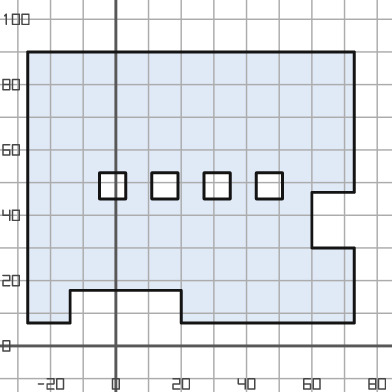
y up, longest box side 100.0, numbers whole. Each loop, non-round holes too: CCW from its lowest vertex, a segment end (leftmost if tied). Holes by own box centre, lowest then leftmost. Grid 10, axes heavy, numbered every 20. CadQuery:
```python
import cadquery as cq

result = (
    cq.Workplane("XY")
    .moveTo(-27.0, 7.0)
    .lineTo(-14.0, 7.0)
    .lineTo(-14.0, 17.0)
    .lineTo(20.0, 17.0)
    .lineTo(20.0, 7.0)
    .lineTo(73.0, 7.0)
    .lineTo(73.0, 30.0)
    .lineTo(60.0, 30.0)
    .lineTo(60.0, 47.0)
    .lineTo(73.0, 47.0)
    .lineTo(73.0, 90.0)
    .lineTo(-27.0, 90.0)
    .close()
    .moveTo(-5.0, 45.0)
    .lineTo(3.0, 45.0)
    .lineTo(3.0, 53.0)
    .lineTo(-5.0, 53.0)
    .close()
    .moveTo(11.0, 45.0)
    .lineTo(19.0, 45.0)
    .lineTo(19.0, 53.0)
    .lineTo(11.0, 53.0)
    .close()
    .moveTo(27.0, 45.0)
    .lineTo(35.0, 45.0)
    .lineTo(35.0, 53.0)
    .lineTo(27.0, 53.0)
    .close()
    .moveTo(43.0, 45.0)
    .lineTo(51.0, 45.0)
    .lineTo(51.0, 53.0)
    .lineTo(43.0, 53.0)
    .close()
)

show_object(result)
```